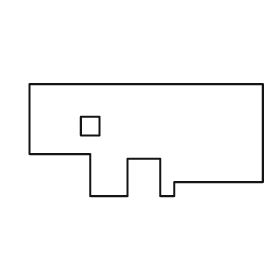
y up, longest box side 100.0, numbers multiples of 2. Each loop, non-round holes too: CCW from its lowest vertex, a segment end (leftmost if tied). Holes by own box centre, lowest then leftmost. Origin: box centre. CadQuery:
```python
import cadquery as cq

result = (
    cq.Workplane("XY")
    .moveTo(-24.0, -24.0)
    .lineTo(-8.0, -24.0)
    .lineTo(-8.0, -8.0)
    .lineTo(6.0, -8.0)
    .lineTo(6.0, -24.0)
    .lineTo(12.0, -24.0)
    .lineTo(12.0, -18.0)
    .lineTo(50.0, -18.0)
    .lineTo(50.0, 24.0)
    .lineTo(-50.0, 24.0)
    .lineTo(-50.0, -6.0)
    .lineTo(-24.0, -6.0)
    .close()
    .moveTo(-28.0, 2.0)
    .lineTo(-20.0, 2.0)
    .lineTo(-20.0, 10.0)
    .lineTo(-28.0, 10.0)
    .close()
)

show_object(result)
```